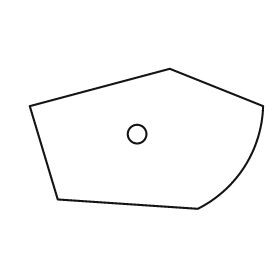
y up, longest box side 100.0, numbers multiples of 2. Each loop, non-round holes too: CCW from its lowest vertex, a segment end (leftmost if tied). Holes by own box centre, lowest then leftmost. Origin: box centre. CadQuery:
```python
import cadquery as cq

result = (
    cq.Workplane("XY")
    .moveTo(22.0, -30.0)
    .threePointArc((42.0, -12.0), (50.0, 14.0))
    .lineTo(10.0, 30.0)
    .lineTo(-50.0, 14.0)
    .lineTo(-38.0, -26.0)
    .close()
    .moveTo(-4.0, 2.0)
    .circle(4.0)
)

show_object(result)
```